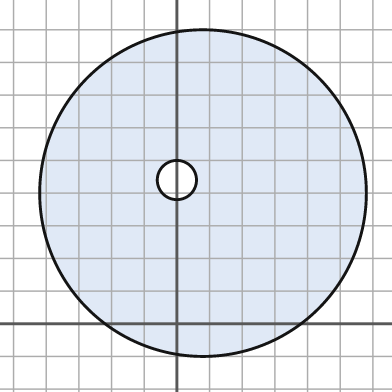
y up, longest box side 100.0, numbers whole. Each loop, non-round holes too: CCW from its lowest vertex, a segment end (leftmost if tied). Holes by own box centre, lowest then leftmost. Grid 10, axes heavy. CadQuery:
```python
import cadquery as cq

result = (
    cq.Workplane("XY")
    .moveTo(8.0, 40.0)
    .circle(50.0)
    .moveTo(0.0, 44.0)
    .circle(6.0)
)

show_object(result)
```